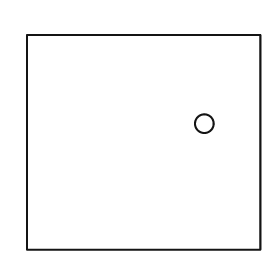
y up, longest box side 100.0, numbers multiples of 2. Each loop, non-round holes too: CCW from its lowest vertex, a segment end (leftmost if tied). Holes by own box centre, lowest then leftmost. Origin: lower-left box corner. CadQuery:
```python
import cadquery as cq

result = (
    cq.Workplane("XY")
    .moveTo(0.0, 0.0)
    .lineTo(100.0, 0.0)
    .lineTo(100.0, 92.0)
    .lineTo(0.0, 92.0)
    .close()
    .moveTo(76.0, 54.0)
    .circle(4.0)
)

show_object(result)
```